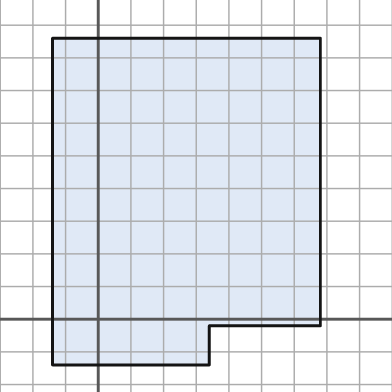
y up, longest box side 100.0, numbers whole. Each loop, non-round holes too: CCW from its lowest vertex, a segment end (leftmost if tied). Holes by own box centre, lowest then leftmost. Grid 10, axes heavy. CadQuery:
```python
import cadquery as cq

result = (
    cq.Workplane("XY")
    .moveTo(-14.0, -14.0)
    .lineTo(34.0, -14.0)
    .lineTo(34.0, -2.0)
    .lineTo(68.0, -2.0)
    .lineTo(68.0, 86.0)
    .lineTo(-14.0, 86.0)
    .close()
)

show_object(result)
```